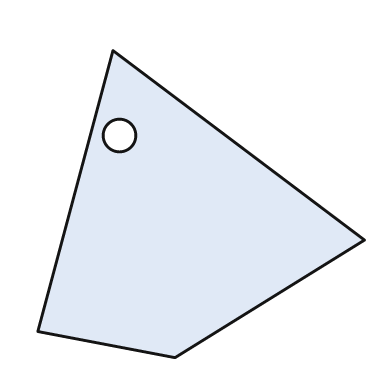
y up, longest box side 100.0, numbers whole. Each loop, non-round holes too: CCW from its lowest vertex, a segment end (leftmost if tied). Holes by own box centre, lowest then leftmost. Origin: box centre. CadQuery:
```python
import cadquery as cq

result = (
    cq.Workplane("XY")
    .moveTo(-8.0, -47.0)
    .lineTo(50.0, -11.0)
    .lineTo(-27.0, 47.0)
    .lineTo(-50.0, -39.0)
    .close()
    .moveTo(-25.0, 21.0)
    .circle(5.0)
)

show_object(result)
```